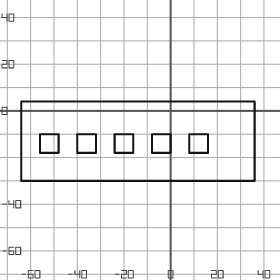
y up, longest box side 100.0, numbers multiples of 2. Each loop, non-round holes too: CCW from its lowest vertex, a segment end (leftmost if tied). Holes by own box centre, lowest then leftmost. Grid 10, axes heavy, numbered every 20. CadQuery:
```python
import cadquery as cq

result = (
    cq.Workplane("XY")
    .moveTo(-64.0, -30.0)
    .lineTo(36.0, -30.0)
    .lineTo(36.0, 4.0)
    .lineTo(-64.0, 4.0)
    .close()
    .moveTo(-56.0, -18.0)
    .lineTo(-48.0, -18.0)
    .lineTo(-48.0, -10.0)
    .lineTo(-56.0, -10.0)
    .close()
    .moveTo(-40.0, -18.0)
    .lineTo(-32.0, -18.0)
    .lineTo(-32.0, -10.0)
    .lineTo(-40.0, -10.0)
    .close()
    .moveTo(-24.0, -18.0)
    .lineTo(-16.0, -18.0)
    .lineTo(-16.0, -10.0)
    .lineTo(-24.0, -10.0)
    .close()
    .moveTo(-8.0, -18.0)
    .lineTo(0.0, -18.0)
    .lineTo(0.0, -10.0)
    .lineTo(-8.0, -10.0)
    .close()
    .moveTo(8.0, -18.0)
    .lineTo(16.0, -18.0)
    .lineTo(16.0, -10.0)
    .lineTo(8.0, -10.0)
    .close()
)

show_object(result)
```